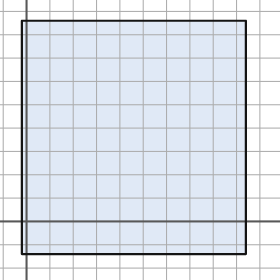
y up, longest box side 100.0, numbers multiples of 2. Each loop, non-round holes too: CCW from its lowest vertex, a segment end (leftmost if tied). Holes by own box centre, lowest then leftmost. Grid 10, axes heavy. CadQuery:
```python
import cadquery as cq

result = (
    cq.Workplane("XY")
    .moveTo(-2.0, -14.0)
    .lineTo(94.0, -14.0)
    .lineTo(94.0, 86.0)
    .lineTo(-2.0, 86.0)
    .close()
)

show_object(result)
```